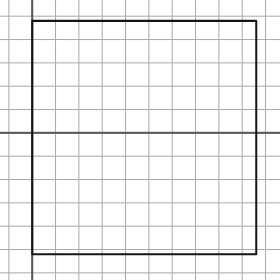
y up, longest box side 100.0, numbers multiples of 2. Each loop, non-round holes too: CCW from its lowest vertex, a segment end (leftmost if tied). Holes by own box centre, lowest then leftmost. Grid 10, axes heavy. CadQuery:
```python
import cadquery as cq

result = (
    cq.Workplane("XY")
    .moveTo(0.0, -52.0)
    .lineTo(96.0, -52.0)
    .lineTo(96.0, 48.0)
    .lineTo(0.0, 48.0)
    .close()
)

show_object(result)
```